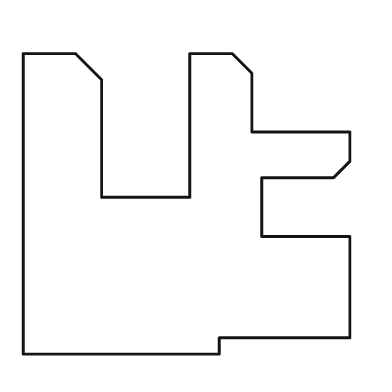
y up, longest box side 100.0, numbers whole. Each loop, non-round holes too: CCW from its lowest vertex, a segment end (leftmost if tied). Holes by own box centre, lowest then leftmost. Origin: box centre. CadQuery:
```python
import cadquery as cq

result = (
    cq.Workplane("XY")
    .moveTo(-50.0, -46.0)
    .lineTo(10.0, -46.0)
    .lineTo(10.0, -41.0)
    .lineTo(50.0, -41.0)
    .lineTo(50.0, -10.0)
    .lineTo(23.0, -10.0)
    .lineTo(23.0, 8.0)
    .lineTo(45.0, 8.0)
    .lineTo(50.0, 13.0)
    .lineTo(50.0, 22.0)
    .lineTo(20.0, 22.0)
    .lineTo(20.0, 40.0)
    .lineTo(14.0, 46.0)
    .lineTo(1.0, 46.0)
    .lineTo(1.0, 2.0)
    .lineTo(-26.0, 2.0)
    .lineTo(-26.0, 38.0)
    .lineTo(-34.0, 46.0)
    .lineTo(-50.0, 46.0)
    .close()
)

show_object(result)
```